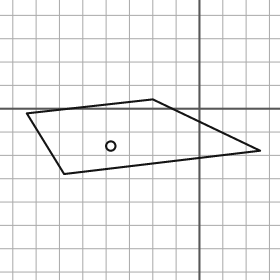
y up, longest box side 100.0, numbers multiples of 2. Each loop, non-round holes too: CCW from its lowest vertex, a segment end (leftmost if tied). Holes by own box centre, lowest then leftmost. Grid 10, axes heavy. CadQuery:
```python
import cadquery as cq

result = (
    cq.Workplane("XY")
    .moveTo(-58.0, -28.0)
    .lineTo(26.0, -18.0)
    .lineTo(-20.0, 4.0)
    .lineTo(-74.0, -2.0)
    .close()
    .moveTo(-38.0, -16.0)
    .circle(2.0)
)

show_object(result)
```